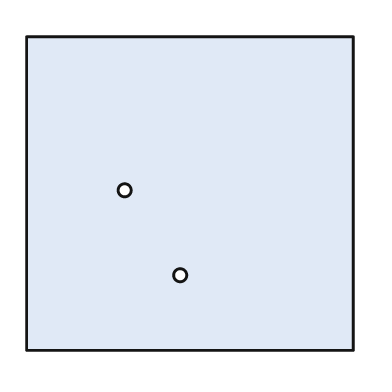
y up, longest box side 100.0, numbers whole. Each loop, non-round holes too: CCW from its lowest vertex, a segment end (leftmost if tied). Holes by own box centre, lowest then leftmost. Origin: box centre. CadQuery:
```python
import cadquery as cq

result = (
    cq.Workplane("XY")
    .moveTo(-50.0, -48.0)
    .lineTo(50.0, -48.0)
    .lineTo(50.0, 48.0)
    .lineTo(-50.0, 48.0)
    .close()
    .moveTo(-3.0, -25.0)
    .circle(2.0)
    .moveTo(-20.0, 1.0)
    .circle(2.0)
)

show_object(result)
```